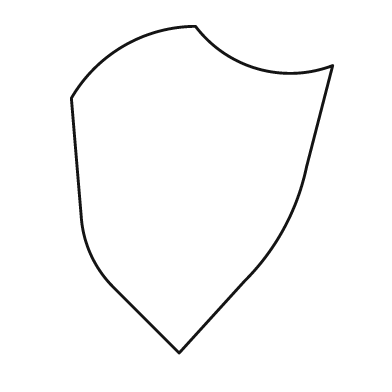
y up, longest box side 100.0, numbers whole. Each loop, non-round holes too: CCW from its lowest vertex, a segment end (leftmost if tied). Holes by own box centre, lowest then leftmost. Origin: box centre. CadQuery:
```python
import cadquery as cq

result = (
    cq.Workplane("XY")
    .moveTo(-7.0, -50.0)
    .lineTo(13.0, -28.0)
    .threePointArc((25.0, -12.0), (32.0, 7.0))
    .lineTo(40.0, 38.0)
    .threePointArc((17.0, 37.0), (-2.0, 50.0))
    .threePointArc((-24.0, 44.0), (-40.0, 28.0))
    .lineTo(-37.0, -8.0)
    .threePointArc((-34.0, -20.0), (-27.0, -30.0))
    .close()
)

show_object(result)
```